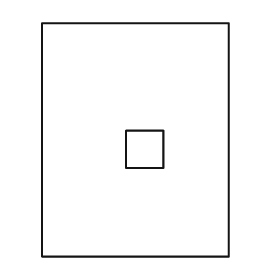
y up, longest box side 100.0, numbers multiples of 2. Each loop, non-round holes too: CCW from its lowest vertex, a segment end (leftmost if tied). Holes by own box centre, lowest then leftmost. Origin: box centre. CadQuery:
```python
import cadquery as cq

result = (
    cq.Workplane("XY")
    .moveTo(-40.0, -50.0)
    .lineTo(40.0, -50.0)
    .lineTo(40.0, 50.0)
    .lineTo(-40.0, 50.0)
    .close()
    .moveTo(-4.0, -12.0)
    .lineTo(12.0, -12.0)
    .lineTo(12.0, 4.0)
    .lineTo(-4.0, 4.0)
    .close()
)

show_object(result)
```